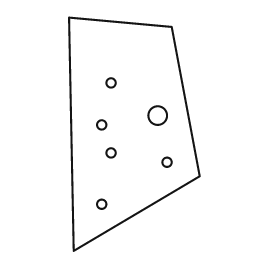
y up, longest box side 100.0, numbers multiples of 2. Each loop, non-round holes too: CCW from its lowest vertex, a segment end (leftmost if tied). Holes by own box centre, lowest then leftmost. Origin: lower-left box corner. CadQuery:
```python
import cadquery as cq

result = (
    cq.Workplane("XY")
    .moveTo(2.0, 0.0)
    .lineTo(56.0, 32.0)
    .lineTo(44.0, 96.0)
    .lineTo(0.0, 100.0)
    .close()
    .moveTo(14.0, 20.0)
    .circle(2.0)
    .moveTo(42.0, 38.0)
    .circle(2.0)
    .moveTo(18.0, 42.0)
    .circle(2.0)
    .moveTo(14.0, 54.0)
    .circle(2.0)
    .moveTo(38.0, 58.0)
    .circle(4.0)
    .moveTo(18.0, 72.0)
    .circle(2.0)
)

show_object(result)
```